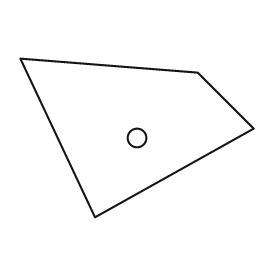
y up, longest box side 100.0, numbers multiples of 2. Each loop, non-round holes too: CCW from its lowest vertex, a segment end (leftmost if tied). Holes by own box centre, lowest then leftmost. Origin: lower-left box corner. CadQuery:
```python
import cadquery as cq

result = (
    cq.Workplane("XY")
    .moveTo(32.0, 0.0)
    .lineTo(100.0, 38.0)
    .lineTo(76.0, 62.0)
    .lineTo(0.0, 68.0)
    .close()
    .moveTo(50.0, 34.0)
    .circle(4.0)
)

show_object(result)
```